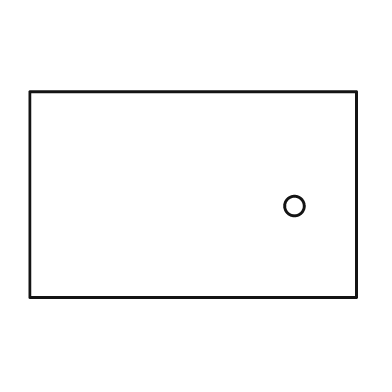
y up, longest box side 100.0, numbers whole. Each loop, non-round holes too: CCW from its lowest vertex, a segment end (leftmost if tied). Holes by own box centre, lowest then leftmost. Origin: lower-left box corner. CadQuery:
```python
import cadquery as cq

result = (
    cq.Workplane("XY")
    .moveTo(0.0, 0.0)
    .lineTo(100.0, 0.0)
    .lineTo(100.0, 63.0)
    .lineTo(0.0, 63.0)
    .close()
    .moveTo(81.0, 28.0)
    .circle(3.0)
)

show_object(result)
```